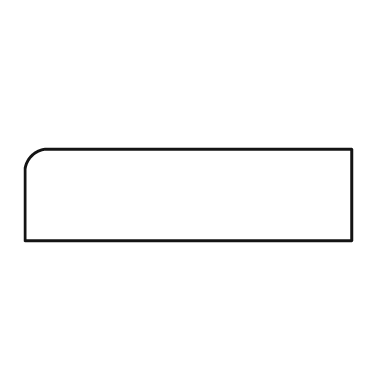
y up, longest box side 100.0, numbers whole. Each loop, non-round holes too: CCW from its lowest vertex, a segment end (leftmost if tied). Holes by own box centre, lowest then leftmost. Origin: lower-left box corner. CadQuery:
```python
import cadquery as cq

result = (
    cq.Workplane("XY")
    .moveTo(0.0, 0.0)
    .lineTo(100.0, 0.0)
    .lineTo(100.0, 28.0)
    .lineTo(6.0, 28.0)
    .threePointArc((2.0, 26.0), (0.0, 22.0))
    .close()
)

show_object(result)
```